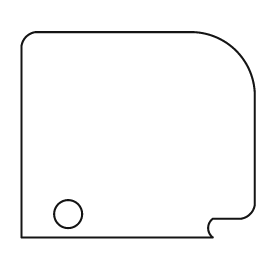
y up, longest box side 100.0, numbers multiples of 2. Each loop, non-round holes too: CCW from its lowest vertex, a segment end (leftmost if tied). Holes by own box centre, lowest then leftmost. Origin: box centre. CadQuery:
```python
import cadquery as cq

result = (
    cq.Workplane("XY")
    .moveTo(-50.0, -44.0)
    .lineTo(32.0, -44.0)
    .threePointArc((30.0, -40.0), (32.0, -36.0))
    .lineTo(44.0, -36.0)
    .threePointArc((48.0, -34.0), (50.0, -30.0))
    .lineTo(50.0, 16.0)
    .threePointArc((42.0, 36.0), (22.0, 44.0))
    .lineTo(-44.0, 44.0)
    .threePointArc((-48.0, 42.0), (-50.0, 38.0))
    .close()
    .moveTo(-30.0, -34.0)
    .circle(6.0)
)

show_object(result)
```